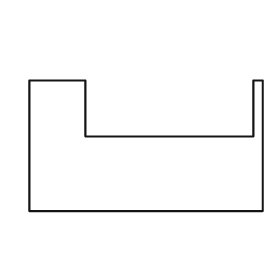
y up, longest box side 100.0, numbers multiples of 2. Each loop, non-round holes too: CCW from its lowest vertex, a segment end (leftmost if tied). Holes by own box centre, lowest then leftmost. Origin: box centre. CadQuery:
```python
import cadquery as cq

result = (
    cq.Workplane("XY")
    .moveTo(-50.0, -28.0)
    .lineTo(50.0, -28.0)
    .lineTo(50.0, 28.0)
    .lineTo(46.0, 28.0)
    .lineTo(46.0, 4.0)
    .lineTo(-26.0, 4.0)
    .lineTo(-26.0, 28.0)
    .lineTo(-50.0, 28.0)
    .close()
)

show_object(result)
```